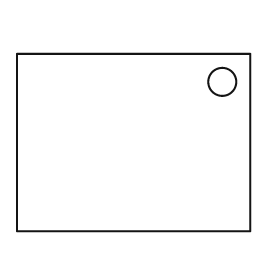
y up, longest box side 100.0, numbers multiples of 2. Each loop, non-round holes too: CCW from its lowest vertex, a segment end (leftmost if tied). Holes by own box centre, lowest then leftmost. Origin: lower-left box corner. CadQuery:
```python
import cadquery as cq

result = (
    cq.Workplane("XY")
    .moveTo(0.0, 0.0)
    .lineTo(100.0, 0.0)
    .lineTo(100.0, 76.0)
    .lineTo(0.0, 76.0)
    .close()
    .moveTo(88.0, 64.0)
    .circle(6.0)
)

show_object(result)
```